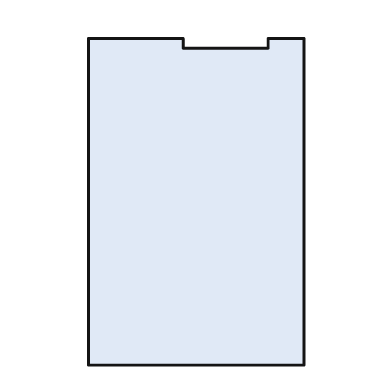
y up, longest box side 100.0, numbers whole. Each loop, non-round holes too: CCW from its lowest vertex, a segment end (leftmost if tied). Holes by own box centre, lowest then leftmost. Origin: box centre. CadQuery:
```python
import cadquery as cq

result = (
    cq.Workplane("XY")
    .moveTo(-33.0, -50.0)
    .lineTo(33.0, -50.0)
    .lineTo(33.0, 50.0)
    .lineTo(22.0, 50.0)
    .lineTo(22.0, 47.0)
    .lineTo(-4.0, 47.0)
    .lineTo(-4.0, 50.0)
    .lineTo(-33.0, 50.0)
    .close()
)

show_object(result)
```